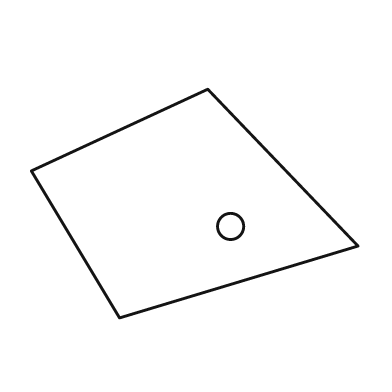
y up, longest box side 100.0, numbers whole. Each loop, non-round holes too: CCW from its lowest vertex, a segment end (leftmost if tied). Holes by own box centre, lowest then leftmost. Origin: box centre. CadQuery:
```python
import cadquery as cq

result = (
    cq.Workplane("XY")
    .moveTo(-23.0, -35.0)
    .lineTo(50.0, -13.0)
    .lineTo(4.0, 35.0)
    .lineTo(-50.0, 10.0)
    .close()
    .moveTo(11.0, -7.0)
    .circle(4.0)
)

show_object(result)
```